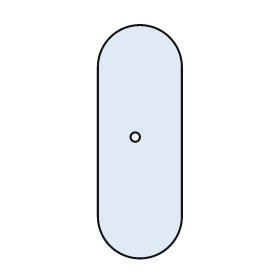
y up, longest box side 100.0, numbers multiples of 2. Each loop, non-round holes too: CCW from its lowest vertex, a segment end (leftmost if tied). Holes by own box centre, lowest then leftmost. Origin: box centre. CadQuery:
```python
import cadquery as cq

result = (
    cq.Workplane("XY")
    .moveTo(-18.0, -32.0)
    .threePointArc((0.0, -50.0), (18.0, -32.0))
    .lineTo(18.0, 32.0)
    .threePointArc((0.0, 50.0), (-18.0, 32.0))
    .close()
    .moveTo(-2.0, 2.0)
    .circle(2.0)
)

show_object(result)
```